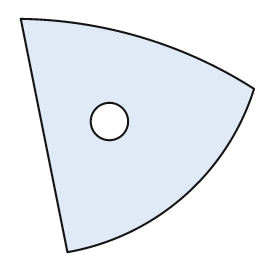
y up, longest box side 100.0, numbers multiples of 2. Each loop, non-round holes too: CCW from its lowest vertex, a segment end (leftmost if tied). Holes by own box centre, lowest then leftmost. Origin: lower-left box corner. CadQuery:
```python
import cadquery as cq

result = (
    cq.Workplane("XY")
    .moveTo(20.0, 0.0)
    .threePointArc((70.0, 24.0), (100.0, 70.0))
    .threePointArc((52.0, 92.0), (0.0, 100.0))
    .close()
    .moveTo(38.0, 56.0)
    .circle(8.0)
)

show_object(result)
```